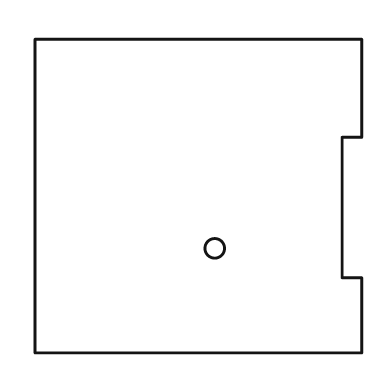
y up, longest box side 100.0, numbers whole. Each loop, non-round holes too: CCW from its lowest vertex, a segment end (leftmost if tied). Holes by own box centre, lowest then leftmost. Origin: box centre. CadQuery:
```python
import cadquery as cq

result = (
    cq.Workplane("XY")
    .moveTo(-50.0, -48.0)
    .lineTo(50.0, -48.0)
    .lineTo(50.0, -25.0)
    .lineTo(44.0, -25.0)
    .lineTo(44.0, 18.0)
    .lineTo(50.0, 18.0)
    .lineTo(50.0, 48.0)
    .lineTo(-50.0, 48.0)
    .close()
    .moveTo(5.0, -16.0)
    .circle(3.0)
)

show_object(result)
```